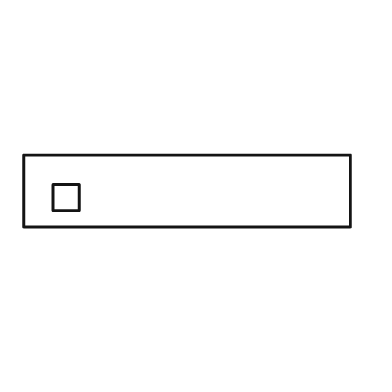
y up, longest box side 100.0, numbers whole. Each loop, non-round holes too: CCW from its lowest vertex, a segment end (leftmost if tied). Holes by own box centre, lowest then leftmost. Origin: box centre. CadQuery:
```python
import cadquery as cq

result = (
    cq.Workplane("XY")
    .moveTo(-50.0, -11.0)
    .lineTo(50.0, -11.0)
    .lineTo(50.0, 11.0)
    .lineTo(-50.0, 11.0)
    .close()
    .moveTo(-41.0, -6.0)
    .lineTo(-33.0, -6.0)
    .lineTo(-33.0, 2.0)
    .lineTo(-41.0, 2.0)
    .close()
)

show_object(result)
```